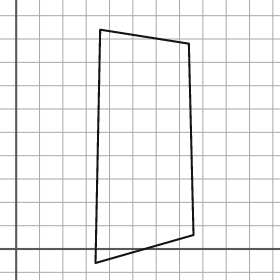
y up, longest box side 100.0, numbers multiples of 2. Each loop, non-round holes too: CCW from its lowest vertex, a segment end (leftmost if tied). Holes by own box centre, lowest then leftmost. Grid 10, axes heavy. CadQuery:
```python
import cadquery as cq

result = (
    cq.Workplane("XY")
    .moveTo(34.0, -6.0)
    .lineTo(76.0, 6.0)
    .lineTo(74.0, 88.0)
    .lineTo(36.0, 94.0)
    .close()
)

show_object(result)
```